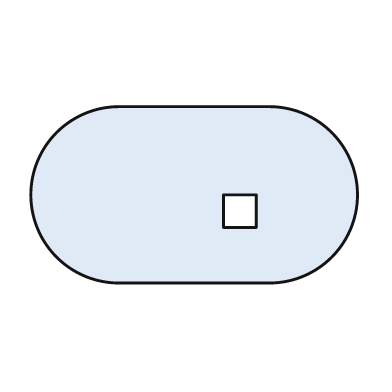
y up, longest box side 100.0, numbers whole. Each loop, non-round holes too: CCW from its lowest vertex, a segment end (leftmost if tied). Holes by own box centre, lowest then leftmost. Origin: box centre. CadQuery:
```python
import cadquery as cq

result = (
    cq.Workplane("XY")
    .moveTo(-23.0, -27.0)
    .lineTo(23.0, -27.0)
    .threePointArc((50.0, 0.0), (23.0, 27.0))
    .lineTo(-23.0, 27.0)
    .threePointArc((-50.0, 0.0), (-23.0, -27.0))
    .close()
    .moveTo(9.0, -10.0)
    .lineTo(19.0, -10.0)
    .lineTo(19.0, 0.0)
    .lineTo(9.0, 0.0)
    .close()
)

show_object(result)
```